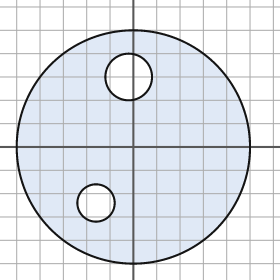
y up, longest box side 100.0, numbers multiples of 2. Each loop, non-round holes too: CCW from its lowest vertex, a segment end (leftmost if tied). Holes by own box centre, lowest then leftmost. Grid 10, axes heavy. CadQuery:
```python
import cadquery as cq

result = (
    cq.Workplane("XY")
    .moveTo(0.0, 0.0)
    .circle(50.0)
    .moveTo(-16.0, -24.0)
    .circle(8.0)
    .moveTo(-2.0, 30.0)
    .circle(10.0)
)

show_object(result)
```